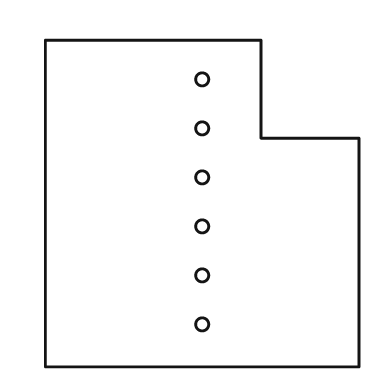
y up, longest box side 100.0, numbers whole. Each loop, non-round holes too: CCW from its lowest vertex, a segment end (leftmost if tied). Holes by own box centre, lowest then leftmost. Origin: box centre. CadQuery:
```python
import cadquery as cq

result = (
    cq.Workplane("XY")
    .moveTo(-48.0, -50.0)
    .lineTo(48.0, -50.0)
    .lineTo(48.0, 20.0)
    .lineTo(18.0, 20.0)
    .lineTo(18.0, 50.0)
    .lineTo(-48.0, 50.0)
    .close()
    .moveTo(0.0, -37.0)
    .circle(2.0)
    .moveTo(0.0, -22.0)
    .circle(2.0)
    .moveTo(0.0, -7.0)
    .circle(2.0)
    .moveTo(0.0, 8.0)
    .circle(2.0)
    .moveTo(0.0, 23.0)
    .circle(2.0)
    .moveTo(0.0, 38.0)
    .circle(2.0)
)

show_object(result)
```